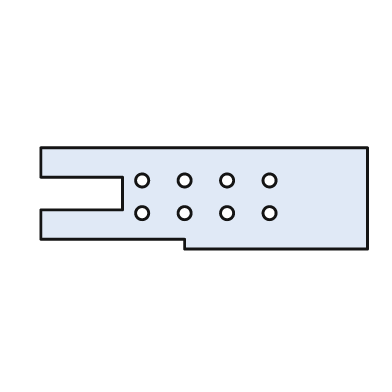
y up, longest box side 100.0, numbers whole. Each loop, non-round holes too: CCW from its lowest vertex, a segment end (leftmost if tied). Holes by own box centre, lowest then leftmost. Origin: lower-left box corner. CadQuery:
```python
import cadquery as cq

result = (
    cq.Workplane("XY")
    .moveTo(44.0, 0.0)
    .lineTo(100.0, 0.0)
    .lineTo(100.0, 31.0)
    .lineTo(0.0, 31.0)
    .lineTo(0.0, 22.0)
    .lineTo(25.0, 22.0)
    .lineTo(25.0, 12.0)
    .lineTo(0.0, 12.0)
    .lineTo(0.0, 3.0)
    .lineTo(44.0, 3.0)
    .close()
    .moveTo(31.0, 11.0)
    .circle(2.0)
    .moveTo(44.0, 11.0)
    .circle(2.0)
    .moveTo(57.0, 11.0)
    .circle(2.0)
    .moveTo(70.0, 11.0)
    .circle(2.0)
    .moveTo(31.0, 21.0)
    .circle(2.0)
    .moveTo(44.0, 21.0)
    .circle(2.0)
    .moveTo(57.0, 21.0)
    .circle(2.0)
    .moveTo(70.0, 21.0)
    .circle(2.0)
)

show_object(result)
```